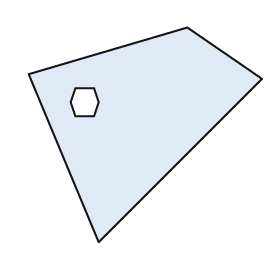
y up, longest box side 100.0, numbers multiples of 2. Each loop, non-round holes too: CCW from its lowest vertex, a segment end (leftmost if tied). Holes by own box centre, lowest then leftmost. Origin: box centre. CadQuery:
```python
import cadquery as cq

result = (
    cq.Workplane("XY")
    .moveTo(-20.0, -46.0)
    .lineTo(50.0, 24.0)
    .lineTo(18.0, 46.0)
    .lineTo(-50.0, 26.0)
    .close()
    .moveTo(-30.0, 8.0)
    .lineTo(-22.0, 8.0)
    .lineTo(-20.0, 14.0)
    .lineTo(-22.0, 20.0)
    .lineTo(-30.0, 20.0)
    .lineTo(-32.0, 14.0)
    .close()
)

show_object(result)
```